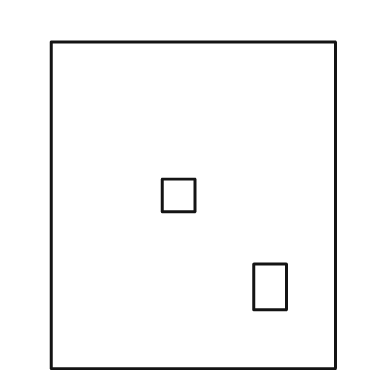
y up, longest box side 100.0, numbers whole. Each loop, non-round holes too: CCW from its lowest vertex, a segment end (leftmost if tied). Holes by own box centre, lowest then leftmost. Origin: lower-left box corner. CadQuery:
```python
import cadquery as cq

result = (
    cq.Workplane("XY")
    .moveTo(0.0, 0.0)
    .lineTo(87.0, 0.0)
    .lineTo(87.0, 100.0)
    .lineTo(0.0, 100.0)
    .close()
    .moveTo(62.0, 18.0)
    .lineTo(72.0, 18.0)
    .lineTo(72.0, 32.0)
    .lineTo(62.0, 32.0)
    .close()
    .moveTo(34.0, 48.0)
    .lineTo(44.0, 48.0)
    .lineTo(44.0, 58.0)
    .lineTo(34.0, 58.0)
    .close()
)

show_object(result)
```